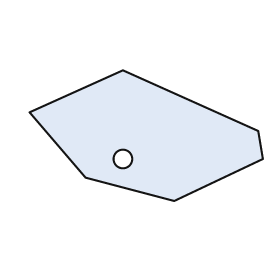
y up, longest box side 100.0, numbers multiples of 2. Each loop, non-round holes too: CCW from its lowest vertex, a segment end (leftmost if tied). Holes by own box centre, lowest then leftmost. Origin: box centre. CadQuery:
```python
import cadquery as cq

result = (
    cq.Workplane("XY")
    .moveTo(12.0, -28.0)
    .lineTo(50.0, -10.0)
    .lineTo(48.0, 2.0)
    .lineTo(-10.0, 28.0)
    .lineTo(-50.0, 10.0)
    .lineTo(-26.0, -18.0)
    .close()
    .moveTo(-10.0, -10.0)
    .circle(4.0)
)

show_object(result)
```